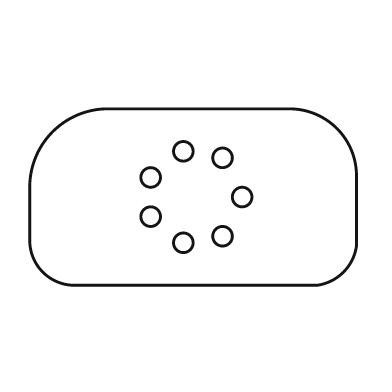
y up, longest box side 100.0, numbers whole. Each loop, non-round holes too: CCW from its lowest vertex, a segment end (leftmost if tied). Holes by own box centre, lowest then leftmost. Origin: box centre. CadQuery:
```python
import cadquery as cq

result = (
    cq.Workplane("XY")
    .moveTo(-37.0, -27.0)
    .lineTo(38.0, -27.0)
    .threePointArc((46.0, -23.0), (50.0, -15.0))
    .lineTo(50.0, 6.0)
    .threePointArc((44.0, 21.0), (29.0, 27.0))
    .lineTo(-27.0, 27.0)
    .threePointArc((-43.0, 20.0), (-50.0, 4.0))
    .lineTo(-50.0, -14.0)
    .threePointArc((-46.0, -23.0), (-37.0, -27.0))
    .close()
    .moveTo(-3.0, -14.0)
    .circle(3.0)
    .moveTo(9.0, -12.0)
    .circle(3.0)
    .moveTo(-13.0, -6.0)
    .circle(3.0)
    .moveTo(15.0, 0.0)
    .circle(3.0)
    .moveTo(-13.0, 6.0)
    .circle(3.0)
    .moveTo(9.0, 12.0)
    .circle(3.0)
    .moveTo(-3.0, 14.0)
    .circle(3.0)
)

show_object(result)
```